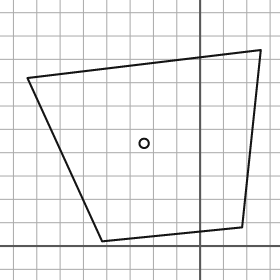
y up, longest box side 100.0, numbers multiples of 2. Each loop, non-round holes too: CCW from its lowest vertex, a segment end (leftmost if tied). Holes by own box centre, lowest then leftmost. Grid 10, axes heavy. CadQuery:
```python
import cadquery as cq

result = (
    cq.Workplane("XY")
    .moveTo(-42.0, 2.0)
    .lineTo(18.0, 8.0)
    .lineTo(26.0, 84.0)
    .lineTo(-74.0, 72.0)
    .close()
    .moveTo(-24.0, 44.0)
    .circle(2.0)
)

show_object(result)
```